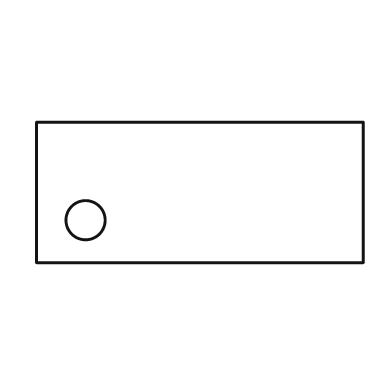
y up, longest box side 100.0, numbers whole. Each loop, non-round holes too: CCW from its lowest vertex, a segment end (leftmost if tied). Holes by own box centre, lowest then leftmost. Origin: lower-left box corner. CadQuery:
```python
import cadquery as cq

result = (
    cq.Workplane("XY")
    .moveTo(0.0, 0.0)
    .lineTo(100.0, 0.0)
    .lineTo(100.0, 43.0)
    .lineTo(0.0, 43.0)
    .close()
    .moveTo(15.0, 13.0)
    .circle(6.0)
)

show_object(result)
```